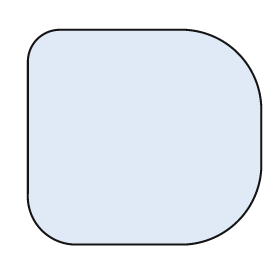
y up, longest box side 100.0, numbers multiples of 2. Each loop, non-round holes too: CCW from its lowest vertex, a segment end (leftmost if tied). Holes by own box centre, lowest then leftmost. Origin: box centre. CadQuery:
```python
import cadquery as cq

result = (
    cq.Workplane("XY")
    .moveTo(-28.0, -46.0)
    .lineTo(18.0, -46.0)
    .threePointArc((40.0, -36.0), (50.0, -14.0))
    .lineTo(50.0, 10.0)
    .threePointArc((40.0, 36.0), (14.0, 46.0))
    .lineTo(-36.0, 46.0)
    .threePointArc((-46.0, 42.0), (-50.0, 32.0))
    .lineTo(-50.0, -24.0)
    .threePointArc((-44.0, -40.0), (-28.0, -46.0))
    .close()
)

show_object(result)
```